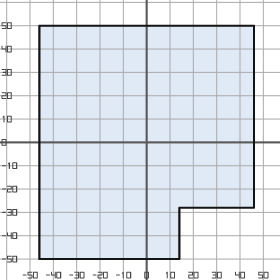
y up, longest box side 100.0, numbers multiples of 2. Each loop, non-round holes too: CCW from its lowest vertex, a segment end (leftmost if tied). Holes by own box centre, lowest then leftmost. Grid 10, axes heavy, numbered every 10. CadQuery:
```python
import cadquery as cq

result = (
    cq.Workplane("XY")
    .moveTo(-46.0, -50.0)
    .lineTo(14.0, -50.0)
    .lineTo(14.0, -28.0)
    .lineTo(46.0, -28.0)
    .lineTo(46.0, 50.0)
    .lineTo(-46.0, 50.0)
    .close()
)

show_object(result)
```